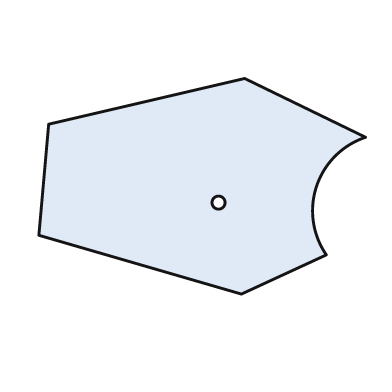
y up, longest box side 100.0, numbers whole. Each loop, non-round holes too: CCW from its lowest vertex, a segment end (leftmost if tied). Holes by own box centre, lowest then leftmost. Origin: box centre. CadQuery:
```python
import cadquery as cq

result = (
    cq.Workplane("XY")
    .moveTo(12.0, -33.0)
    .lineTo(38.0, -21.0)
    .threePointArc((35.0, 0.0), (50.0, 15.0))
    .lineTo(13.0, 33.0)
    .lineTo(-47.0, 19.0)
    .lineTo(-50.0, -15.0)
    .close()
    .moveTo(5.0, -5.0)
    .circle(2.0)
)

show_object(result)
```